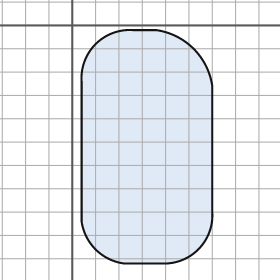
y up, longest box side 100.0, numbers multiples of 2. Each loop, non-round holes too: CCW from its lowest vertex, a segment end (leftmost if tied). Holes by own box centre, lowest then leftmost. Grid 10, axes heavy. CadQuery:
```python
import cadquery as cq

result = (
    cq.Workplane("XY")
    .moveTo(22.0, -102.0)
    .lineTo(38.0, -102.0)
    .threePointArc((54.0, -96.0), (60.0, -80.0))
    .lineTo(60.0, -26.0)
    .threePointArc((52.0, -10.0), (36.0, -2.0))
    .lineTo(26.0, -2.0)
    .threePointArc((10.0, -8.0), (4.0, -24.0))
    .lineTo(4.0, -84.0)
    .threePointArc((10.0, -96.0), (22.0, -102.0))
    .close()
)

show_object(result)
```